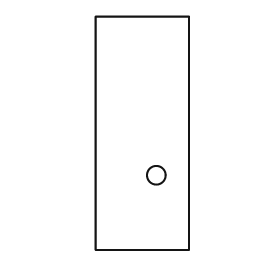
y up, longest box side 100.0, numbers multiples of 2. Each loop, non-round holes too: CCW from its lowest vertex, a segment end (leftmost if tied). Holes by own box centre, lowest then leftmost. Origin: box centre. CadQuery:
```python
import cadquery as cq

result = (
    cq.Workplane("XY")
    .moveTo(-20.0, -50.0)
    .lineTo(20.0, -50.0)
    .lineTo(20.0, 50.0)
    .lineTo(-20.0, 50.0)
    .close()
    .moveTo(6.0, -18.0)
    .circle(4.0)
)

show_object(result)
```